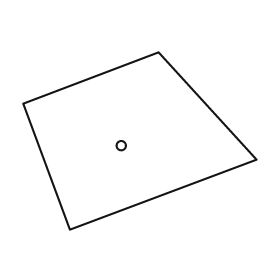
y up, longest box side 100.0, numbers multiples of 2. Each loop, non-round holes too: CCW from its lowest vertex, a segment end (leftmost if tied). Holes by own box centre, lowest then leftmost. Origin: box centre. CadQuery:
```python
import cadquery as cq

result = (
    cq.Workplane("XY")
    .moveTo(-30.0, -38.0)
    .lineTo(50.0, -8.0)
    .lineTo(8.0, 38.0)
    .lineTo(-50.0, 16.0)
    .close()
    .moveTo(-8.0, -2.0)
    .circle(2.0)
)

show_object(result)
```